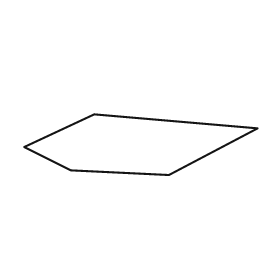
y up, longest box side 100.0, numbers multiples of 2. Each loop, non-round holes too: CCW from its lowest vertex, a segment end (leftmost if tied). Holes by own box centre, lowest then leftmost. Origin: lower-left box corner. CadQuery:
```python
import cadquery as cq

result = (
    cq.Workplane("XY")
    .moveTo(62.0, 0.0)
    .lineTo(100.0, 20.0)
    .lineTo(30.0, 26.0)
    .lineTo(0.0, 12.0)
    .lineTo(20.0, 2.0)
    .close()
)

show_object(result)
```